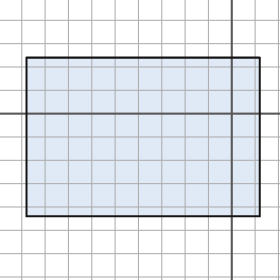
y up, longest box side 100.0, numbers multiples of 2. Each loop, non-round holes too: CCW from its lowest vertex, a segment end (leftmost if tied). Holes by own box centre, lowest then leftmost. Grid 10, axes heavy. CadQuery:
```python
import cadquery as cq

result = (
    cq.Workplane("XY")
    .moveTo(-88.0, -44.0)
    .lineTo(12.0, -44.0)
    .lineTo(12.0, 24.0)
    .lineTo(-88.0, 24.0)
    .close()
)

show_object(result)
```